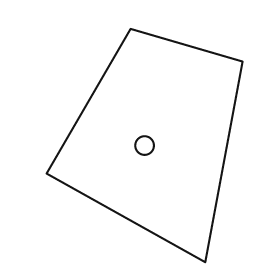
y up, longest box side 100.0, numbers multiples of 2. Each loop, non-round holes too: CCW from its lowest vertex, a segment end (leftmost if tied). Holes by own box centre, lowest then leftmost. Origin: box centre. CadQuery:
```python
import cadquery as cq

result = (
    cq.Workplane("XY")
    .moveTo(26.0, -50.0)
    .lineTo(42.0, 36.0)
    .lineTo(-6.0, 50.0)
    .lineTo(-42.0, -12.0)
    .close()
    .moveTo(0.0, 0.0)
    .circle(4.0)
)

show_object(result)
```